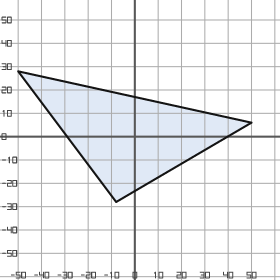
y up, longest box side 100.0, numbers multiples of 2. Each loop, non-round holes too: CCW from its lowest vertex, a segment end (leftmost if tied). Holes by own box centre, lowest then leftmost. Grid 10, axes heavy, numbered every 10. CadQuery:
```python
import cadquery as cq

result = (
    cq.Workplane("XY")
    .moveTo(-8.0, -28.0)
    .lineTo(50.0, 6.0)
    .lineTo(-50.0, 28.0)
    .close()
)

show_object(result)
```